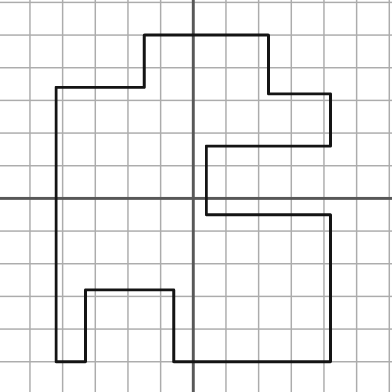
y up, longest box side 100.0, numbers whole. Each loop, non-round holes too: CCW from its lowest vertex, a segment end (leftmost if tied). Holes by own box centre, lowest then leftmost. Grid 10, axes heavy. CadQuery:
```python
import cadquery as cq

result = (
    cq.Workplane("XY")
    .moveTo(-42.0, -50.0)
    .lineTo(-33.0, -50.0)
    .lineTo(-33.0, -28.0)
    .lineTo(-6.0, -28.0)
    .lineTo(-6.0, -50.0)
    .lineTo(42.0, -50.0)
    .lineTo(42.0, -5.0)
    .lineTo(4.0, -5.0)
    .lineTo(4.0, 16.0)
    .lineTo(42.0, 16.0)
    .lineTo(42.0, 32.0)
    .lineTo(23.0, 32.0)
    .lineTo(23.0, 50.0)
    .lineTo(-15.0, 50.0)
    .lineTo(-15.0, 34.0)
    .lineTo(-42.0, 34.0)
    .close()
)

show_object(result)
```